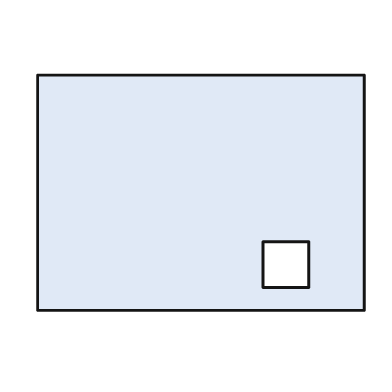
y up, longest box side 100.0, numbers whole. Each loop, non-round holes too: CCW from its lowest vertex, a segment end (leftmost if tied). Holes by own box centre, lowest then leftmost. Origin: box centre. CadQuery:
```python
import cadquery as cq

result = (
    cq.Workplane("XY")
    .moveTo(-50.0, -36.0)
    .lineTo(50.0, -36.0)
    .lineTo(50.0, 36.0)
    .lineTo(-50.0, 36.0)
    .close()
    .moveTo(19.0, -29.0)
    .lineTo(33.0, -29.0)
    .lineTo(33.0, -15.0)
    .lineTo(19.0, -15.0)
    .close()
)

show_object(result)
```